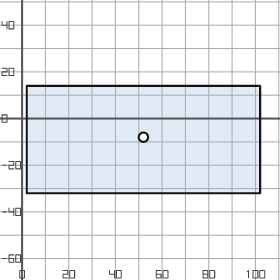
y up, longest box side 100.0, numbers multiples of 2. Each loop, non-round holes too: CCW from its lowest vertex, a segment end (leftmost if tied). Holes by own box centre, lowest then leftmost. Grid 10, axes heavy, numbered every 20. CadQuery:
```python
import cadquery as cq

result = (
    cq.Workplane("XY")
    .moveTo(2.0, -32.0)
    .lineTo(102.0, -32.0)
    .lineTo(102.0, 14.0)
    .lineTo(2.0, 14.0)
    .close()
    .moveTo(52.0, -8.0)
    .circle(2.0)
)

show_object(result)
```